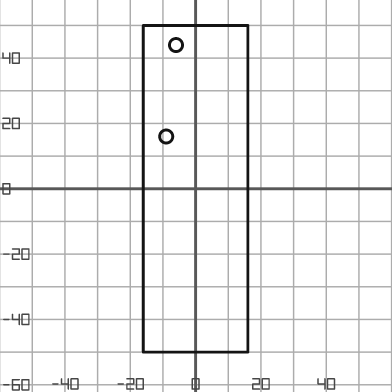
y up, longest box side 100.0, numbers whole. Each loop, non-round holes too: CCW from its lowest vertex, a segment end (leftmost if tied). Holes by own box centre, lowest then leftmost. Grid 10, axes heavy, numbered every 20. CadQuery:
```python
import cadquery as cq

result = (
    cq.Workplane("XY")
    .moveTo(-16.0, -50.0)
    .lineTo(16.0, -50.0)
    .lineTo(16.0, 50.0)
    .lineTo(-16.0, 50.0)
    .close()
    .moveTo(-9.0, 16.0)
    .circle(2.0)
    .moveTo(-6.0, 44.0)
    .circle(2.0)
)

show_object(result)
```